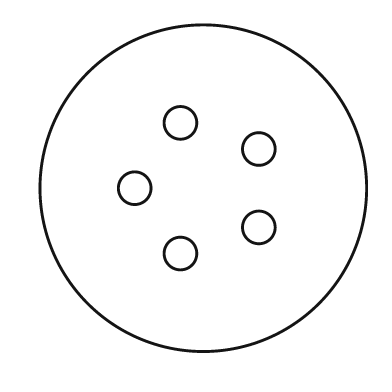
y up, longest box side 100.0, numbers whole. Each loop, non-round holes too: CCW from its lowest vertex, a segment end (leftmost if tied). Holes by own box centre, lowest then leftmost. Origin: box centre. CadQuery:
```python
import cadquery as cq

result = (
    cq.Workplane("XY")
    .moveTo(0.0, 0.0)
    .circle(50.0)
    .moveTo(-7.0, -20.0)
    .circle(5.0)
    .moveTo(17.0, -12.0)
    .circle(5.0)
    .moveTo(-21.0, 0.0)
    .circle(5.0)
    .moveTo(17.0, 12.0)
    .circle(5.0)
    .moveTo(-7.0, 20.0)
    .circle(5.0)
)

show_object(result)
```